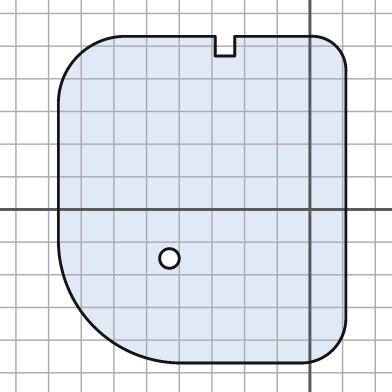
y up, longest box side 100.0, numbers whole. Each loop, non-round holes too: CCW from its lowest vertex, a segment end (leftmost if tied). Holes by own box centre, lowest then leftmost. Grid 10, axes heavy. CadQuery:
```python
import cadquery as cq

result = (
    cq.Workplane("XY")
    .moveTo(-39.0, -47.0)
    .lineTo(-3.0, -47.0)
    .threePointArc((7.0, -43.0), (11.0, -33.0))
    .lineTo(11.0, 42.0)
    .threePointArc((8.0, 50.0), (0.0, 53.0))
    .lineTo(-23.0, 53.0)
    .lineTo(-23.0, 47.0)
    .lineTo(-29.0, 47.0)
    .lineTo(-29.0, 53.0)
    .lineTo(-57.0, 53.0)
    .threePointArc((-71.0, 47.0), (-77.0, 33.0))
    .lineTo(-77.0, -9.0)
    .threePointArc((-66.0, -36.0), (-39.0, -47.0))
    .close()
    .moveTo(-43.0, -15.0)
    .circle(3.0)
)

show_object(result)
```